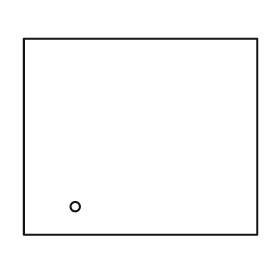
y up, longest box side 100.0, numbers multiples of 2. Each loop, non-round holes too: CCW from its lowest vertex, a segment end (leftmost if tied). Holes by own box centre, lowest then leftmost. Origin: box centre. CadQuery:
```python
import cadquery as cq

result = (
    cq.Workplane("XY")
    .moveTo(-50.0, -42.0)
    .lineTo(50.0, -42.0)
    .lineTo(50.0, 42.0)
    .lineTo(-50.0, 42.0)
    .close()
    .moveTo(-28.0, -30.0)
    .circle(2.0)
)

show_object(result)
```